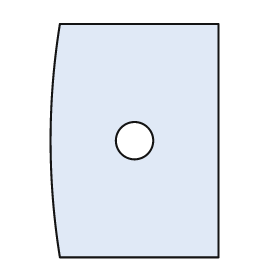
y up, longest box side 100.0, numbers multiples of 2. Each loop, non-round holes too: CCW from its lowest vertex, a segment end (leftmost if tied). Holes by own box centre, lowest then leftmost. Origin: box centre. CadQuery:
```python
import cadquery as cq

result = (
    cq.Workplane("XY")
    .moveTo(-32.0, -50.0)
    .lineTo(36.0, -50.0)
    .lineTo(36.0, 50.0)
    .lineTo(-32.0, 50.0)
    .threePointArc((-36.0, 0.0), (-32.0, -50.0))
    .close()
    .moveTo(0.0, 0.0)
    .circle(8.0)
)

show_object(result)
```